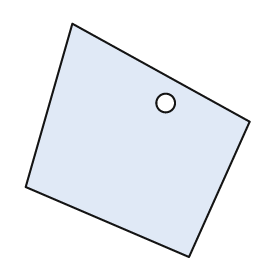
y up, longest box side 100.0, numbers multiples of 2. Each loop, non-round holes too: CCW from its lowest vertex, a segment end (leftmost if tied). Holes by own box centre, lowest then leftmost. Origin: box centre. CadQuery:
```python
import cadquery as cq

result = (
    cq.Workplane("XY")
    .moveTo(22.0, -50.0)
    .lineTo(48.0, 8.0)
    .lineTo(-28.0, 50.0)
    .lineTo(-48.0, -20.0)
    .close()
    .moveTo(12.0, 16.0)
    .circle(4.0)
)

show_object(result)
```